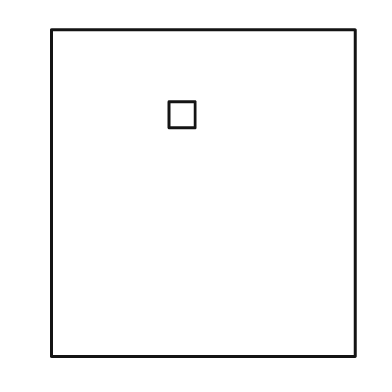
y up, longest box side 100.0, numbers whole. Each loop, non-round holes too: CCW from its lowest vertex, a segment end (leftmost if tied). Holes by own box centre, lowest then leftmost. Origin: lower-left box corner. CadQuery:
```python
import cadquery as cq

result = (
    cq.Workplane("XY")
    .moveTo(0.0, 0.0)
    .lineTo(93.0, 0.0)
    .lineTo(93.0, 100.0)
    .lineTo(0.0, 100.0)
    .close()
    .moveTo(36.0, 70.0)
    .lineTo(44.0, 70.0)
    .lineTo(44.0, 78.0)
    .lineTo(36.0, 78.0)
    .close()
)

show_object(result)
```